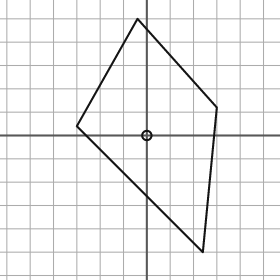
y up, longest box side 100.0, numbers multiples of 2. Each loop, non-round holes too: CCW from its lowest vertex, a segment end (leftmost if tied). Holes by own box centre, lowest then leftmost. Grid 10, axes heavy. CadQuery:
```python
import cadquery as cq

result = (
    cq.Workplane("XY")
    .moveTo(24.0, -50.0)
    .lineTo(30.0, 12.0)
    .lineTo(-4.0, 50.0)
    .lineTo(-30.0, 4.0)
    .close()
    .moveTo(0.0, 0.0)
    .circle(2.0)
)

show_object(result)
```